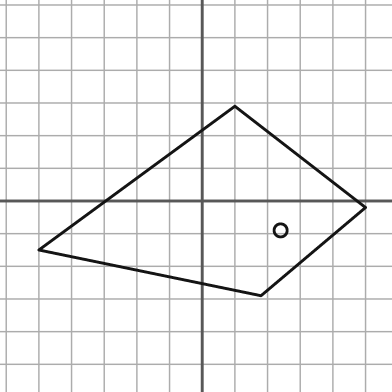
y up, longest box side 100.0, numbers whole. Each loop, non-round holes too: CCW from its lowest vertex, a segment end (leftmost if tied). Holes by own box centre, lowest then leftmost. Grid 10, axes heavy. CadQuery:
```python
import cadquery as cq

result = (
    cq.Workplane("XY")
    .moveTo(18.0, -29.0)
    .lineTo(50.0, -2.0)
    .lineTo(10.0, 29.0)
    .lineTo(-50.0, -15.0)
    .close()
    .moveTo(24.0, -9.0)
    .circle(2.0)
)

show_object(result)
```